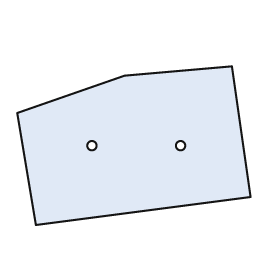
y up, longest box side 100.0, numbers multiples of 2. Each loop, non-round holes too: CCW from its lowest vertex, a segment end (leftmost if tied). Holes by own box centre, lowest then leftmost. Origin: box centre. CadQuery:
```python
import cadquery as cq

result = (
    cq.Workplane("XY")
    .moveTo(-42.0, -34.0)
    .lineTo(50.0, -22.0)
    .lineTo(42.0, 34.0)
    .lineTo(-4.0, 30.0)
    .lineTo(-50.0, 14.0)
    .close()
    .moveTo(-18.0, 0.0)
    .circle(2.0)
    .moveTo(20.0, 0.0)
    .circle(2.0)
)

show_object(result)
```